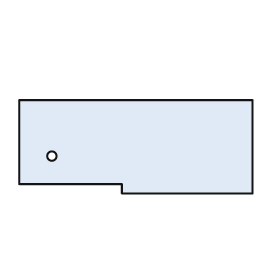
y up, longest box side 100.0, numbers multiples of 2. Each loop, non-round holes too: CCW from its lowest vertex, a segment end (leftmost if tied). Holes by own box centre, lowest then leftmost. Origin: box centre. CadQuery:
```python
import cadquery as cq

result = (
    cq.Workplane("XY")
    .moveTo(-6.0, -20.0)
    .lineTo(50.0, -20.0)
    .lineTo(50.0, 20.0)
    .lineTo(-50.0, 20.0)
    .lineTo(-50.0, -16.0)
    .lineTo(-6.0, -16.0)
    .close()
    .moveTo(-36.0, -4.0)
    .circle(2.0)
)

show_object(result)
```